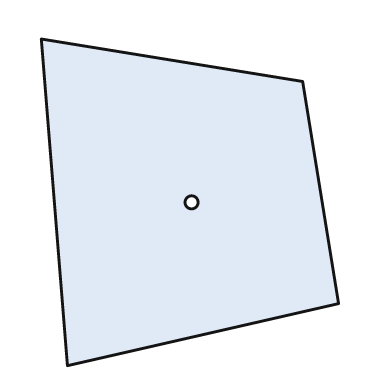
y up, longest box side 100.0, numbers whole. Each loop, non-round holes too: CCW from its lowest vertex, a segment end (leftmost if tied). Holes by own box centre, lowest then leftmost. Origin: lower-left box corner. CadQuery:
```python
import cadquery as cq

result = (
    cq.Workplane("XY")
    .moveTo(8.0, 0.0)
    .lineTo(91.0, 19.0)
    .lineTo(80.0, 87.0)
    .lineTo(0.0, 100.0)
    .close()
    .moveTo(46.0, 50.0)
    .circle(2.0)
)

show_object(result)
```